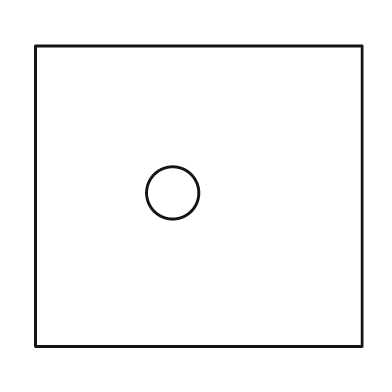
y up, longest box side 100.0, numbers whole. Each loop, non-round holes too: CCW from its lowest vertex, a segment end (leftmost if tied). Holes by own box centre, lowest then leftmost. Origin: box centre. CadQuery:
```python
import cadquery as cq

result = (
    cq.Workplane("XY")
    .moveTo(-50.0, -46.0)
    .lineTo(50.0, -46.0)
    .lineTo(50.0, 46.0)
    .lineTo(-50.0, 46.0)
    .close()
    .moveTo(-8.0, 1.0)
    .circle(8.0)
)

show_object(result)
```